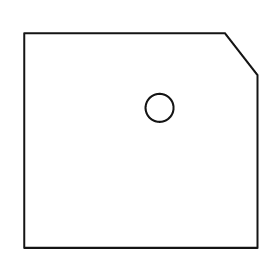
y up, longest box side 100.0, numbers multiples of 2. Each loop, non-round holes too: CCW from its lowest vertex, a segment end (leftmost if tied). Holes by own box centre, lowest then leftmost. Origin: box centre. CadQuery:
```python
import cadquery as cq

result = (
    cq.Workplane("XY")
    .moveTo(-50.0, -46.0)
    .lineTo(50.0, -46.0)
    .lineTo(50.0, 28.0)
    .lineTo(36.0, 46.0)
    .lineTo(-50.0, 46.0)
    .close()
    .moveTo(8.0, 14.0)
    .circle(6.0)
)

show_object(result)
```